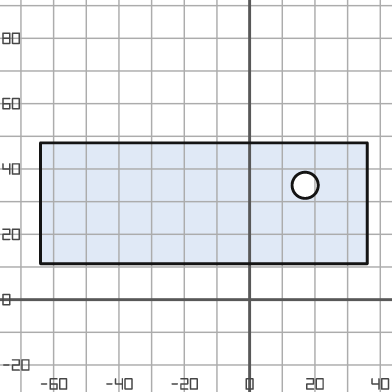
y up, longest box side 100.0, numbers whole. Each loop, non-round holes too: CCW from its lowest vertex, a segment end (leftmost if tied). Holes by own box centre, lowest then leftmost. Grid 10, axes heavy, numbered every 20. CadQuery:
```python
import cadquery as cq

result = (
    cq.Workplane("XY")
    .moveTo(-64.0, 11.0)
    .lineTo(36.0, 11.0)
    .lineTo(36.0, 48.0)
    .lineTo(-64.0, 48.0)
    .close()
    .moveTo(17.0, 35.0)
    .circle(4.0)
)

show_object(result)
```